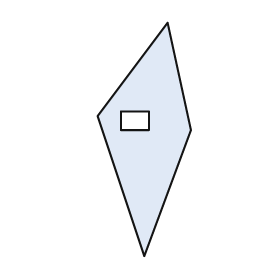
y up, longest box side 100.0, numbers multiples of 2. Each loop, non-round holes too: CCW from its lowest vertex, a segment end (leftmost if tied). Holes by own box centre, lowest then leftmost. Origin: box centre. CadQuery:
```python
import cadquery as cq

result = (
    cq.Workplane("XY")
    .moveTo(0.0, -50.0)
    .lineTo(20.0, 4.0)
    .lineTo(10.0, 50.0)
    .lineTo(-20.0, 10.0)
    .close()
    .moveTo(-10.0, 4.0)
    .lineTo(2.0, 4.0)
    .lineTo(2.0, 12.0)
    .lineTo(-10.0, 12.0)
    .close()
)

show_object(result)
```